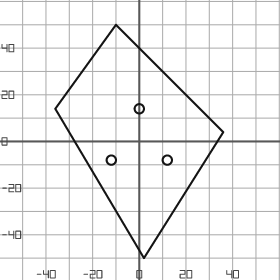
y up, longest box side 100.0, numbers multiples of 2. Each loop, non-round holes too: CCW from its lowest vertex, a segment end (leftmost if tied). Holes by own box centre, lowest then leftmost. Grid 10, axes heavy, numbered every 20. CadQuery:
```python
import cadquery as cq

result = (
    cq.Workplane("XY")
    .moveTo(2.0, -50.0)
    .lineTo(36.0, 4.0)
    .lineTo(-10.0, 50.0)
    .lineTo(-36.0, 14.0)
    .close()
    .moveTo(-12.0, -8.0)
    .circle(2.0)
    .moveTo(12.0, -8.0)
    .circle(2.0)
    .moveTo(0.0, 14.0)
    .circle(2.0)
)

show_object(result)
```